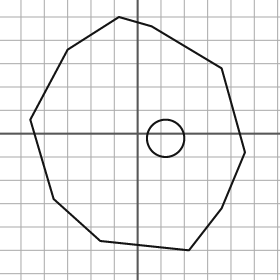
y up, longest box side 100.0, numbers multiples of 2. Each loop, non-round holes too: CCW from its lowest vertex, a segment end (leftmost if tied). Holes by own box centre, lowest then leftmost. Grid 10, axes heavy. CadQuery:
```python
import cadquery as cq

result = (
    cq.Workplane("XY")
    .moveTo(22.0, -50.0)
    .lineTo(36.0, -32.0)
    .lineTo(46.0, -8.0)
    .lineTo(36.0, 28.0)
    .lineTo(6.0, 46.0)
    .lineTo(-8.0, 50.0)
    .lineTo(-30.0, 36.0)
    .lineTo(-46.0, 6.0)
    .lineTo(-36.0, -28.0)
    .lineTo(-16.0, -46.0)
    .close()
    .moveTo(12.0, -2.0)
    .circle(8.0)
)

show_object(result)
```